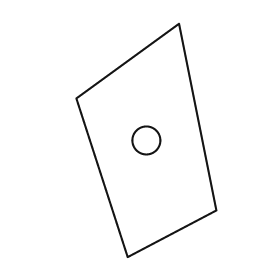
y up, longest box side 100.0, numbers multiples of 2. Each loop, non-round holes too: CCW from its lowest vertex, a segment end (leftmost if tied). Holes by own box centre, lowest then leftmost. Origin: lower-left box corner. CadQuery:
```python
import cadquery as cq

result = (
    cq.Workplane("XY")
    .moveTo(22.0, 0.0)
    .lineTo(60.0, 20.0)
    .lineTo(44.0, 100.0)
    .lineTo(0.0, 68.0)
    .close()
    .moveTo(30.0, 50.0)
    .circle(6.0)
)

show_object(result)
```